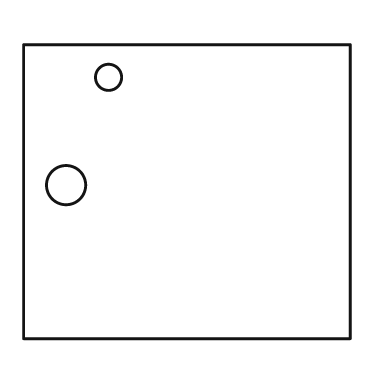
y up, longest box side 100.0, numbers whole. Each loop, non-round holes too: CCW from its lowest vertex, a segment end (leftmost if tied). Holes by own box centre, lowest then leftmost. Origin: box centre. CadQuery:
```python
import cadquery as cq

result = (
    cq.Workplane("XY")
    .moveTo(-50.0, -45.0)
    .lineTo(50.0, -45.0)
    .lineTo(50.0, 45.0)
    .lineTo(-50.0, 45.0)
    .close()
    .moveTo(-37.0, 2.0)
    .circle(6.0)
    .moveTo(-24.0, 35.0)
    .circle(4.0)
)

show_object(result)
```